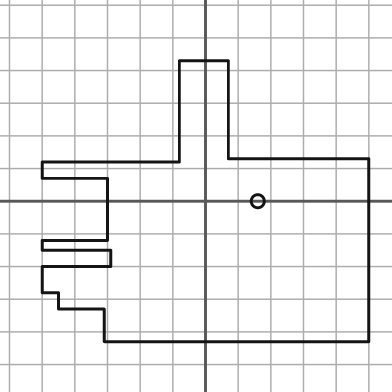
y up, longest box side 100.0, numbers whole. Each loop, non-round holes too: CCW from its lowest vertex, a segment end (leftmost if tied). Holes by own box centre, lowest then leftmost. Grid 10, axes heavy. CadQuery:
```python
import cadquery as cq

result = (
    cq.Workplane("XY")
    .moveTo(-31.0, -43.0)
    .lineTo(50.0, -43.0)
    .lineTo(50.0, 13.0)
    .lineTo(7.0, 13.0)
    .lineTo(7.0, 43.0)
    .lineTo(-8.0, 43.0)
    .lineTo(-8.0, 12.0)
    .lineTo(-50.0, 12.0)
    .lineTo(-50.0, 7.0)
    .lineTo(-30.0, 7.0)
    .lineTo(-30.0, -12.0)
    .lineTo(-50.0, -12.0)
    .lineTo(-50.0, -15.0)
    .lineTo(-29.0, -15.0)
    .lineTo(-29.0, -20.0)
    .lineTo(-50.0, -20.0)
    .lineTo(-50.0, -28.0)
    .lineTo(-45.0, -28.0)
    .lineTo(-45.0, -33.0)
    .lineTo(-31.0, -33.0)
    .close()
    .moveTo(16.0, 0.0)
    .circle(2.0)
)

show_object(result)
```